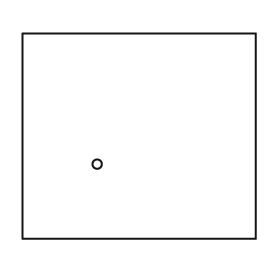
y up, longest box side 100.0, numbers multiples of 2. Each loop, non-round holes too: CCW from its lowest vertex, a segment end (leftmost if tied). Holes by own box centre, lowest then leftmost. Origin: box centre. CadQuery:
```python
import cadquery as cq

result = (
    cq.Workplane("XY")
    .moveTo(-50.0, -44.0)
    .lineTo(50.0, -44.0)
    .lineTo(50.0, 44.0)
    .lineTo(-50.0, 44.0)
    .close()
    .moveTo(-18.0, -12.0)
    .circle(2.0)
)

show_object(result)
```